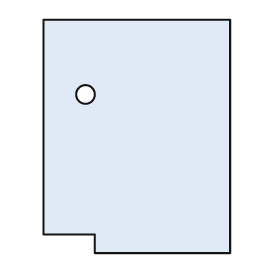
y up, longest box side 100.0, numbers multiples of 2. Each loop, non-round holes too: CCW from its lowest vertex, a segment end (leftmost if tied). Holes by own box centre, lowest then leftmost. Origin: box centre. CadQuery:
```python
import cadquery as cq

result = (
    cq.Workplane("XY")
    .moveTo(-18.0, -50.0)
    .lineTo(40.0, -50.0)
    .lineTo(40.0, 50.0)
    .lineTo(-40.0, 50.0)
    .lineTo(-40.0, -42.0)
    .lineTo(-18.0, -42.0)
    .close()
    .moveTo(-22.0, 18.0)
    .circle(4.0)
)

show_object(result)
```